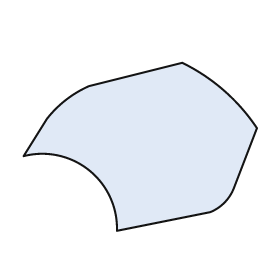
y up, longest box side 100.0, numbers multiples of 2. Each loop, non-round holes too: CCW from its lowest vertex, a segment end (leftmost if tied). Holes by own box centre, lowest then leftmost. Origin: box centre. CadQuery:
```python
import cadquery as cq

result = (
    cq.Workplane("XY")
    .moveTo(-10.0, -36.0)
    .lineTo(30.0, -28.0)
    .threePointArc((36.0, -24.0), (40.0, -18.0))
    .lineTo(50.0, 8.0)
    .threePointArc((36.0, 24.0), (18.0, 36.0))
    .lineTo(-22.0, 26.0)
    .threePointArc((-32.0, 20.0), (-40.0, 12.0))
    .lineTo(-50.0, -4.0)
    .threePointArc((-22.0, -10.0), (-10.0, -36.0))
    .close()
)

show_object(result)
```